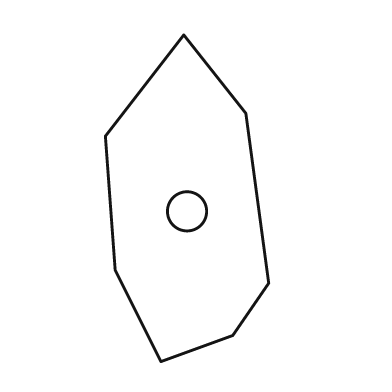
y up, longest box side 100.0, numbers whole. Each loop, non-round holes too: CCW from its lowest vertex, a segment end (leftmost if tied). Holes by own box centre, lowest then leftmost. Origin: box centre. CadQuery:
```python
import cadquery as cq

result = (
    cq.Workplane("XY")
    .moveTo(-8.0, -50.0)
    .lineTo(14.0, -42.0)
    .lineTo(25.0, -26.0)
    .lineTo(18.0, 26.0)
    .lineTo(-1.0, 50.0)
    .lineTo(-25.0, 19.0)
    .lineTo(-22.0, -22.0)
    .close()
    .moveTo(0.0, -4.0)
    .circle(6.0)
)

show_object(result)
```